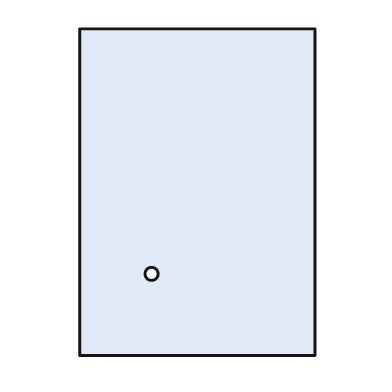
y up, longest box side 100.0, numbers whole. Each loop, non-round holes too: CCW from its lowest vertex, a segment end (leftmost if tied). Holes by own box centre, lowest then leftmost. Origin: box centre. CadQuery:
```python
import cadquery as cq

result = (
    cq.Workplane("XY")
    .moveTo(-36.0, -50.0)
    .lineTo(36.0, -50.0)
    .lineTo(36.0, 50.0)
    .lineTo(-36.0, 50.0)
    .close()
    .moveTo(-14.0, -25.0)
    .circle(2.0)
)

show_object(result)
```